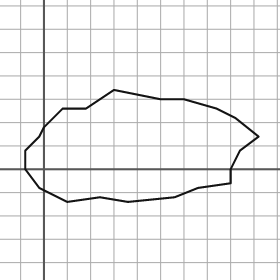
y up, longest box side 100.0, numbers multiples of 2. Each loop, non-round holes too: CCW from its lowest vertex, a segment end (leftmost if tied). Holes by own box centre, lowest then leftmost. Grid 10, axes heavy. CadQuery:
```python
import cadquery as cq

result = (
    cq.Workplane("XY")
    .moveTo(10.0, -14.0)
    .lineTo(24.0, -12.0)
    .lineTo(36.0, -14.0)
    .lineTo(56.0, -12.0)
    .lineTo(66.0, -8.0)
    .lineTo(80.0, -6.0)
    .lineTo(80.0, 0.0)
    .lineTo(84.0, 8.0)
    .lineTo(92.0, 14.0)
    .lineTo(82.0, 22.0)
    .lineTo(74.0, 26.0)
    .lineTo(60.0, 30.0)
    .lineTo(50.0, 30.0)
    .lineTo(30.0, 34.0)
    .lineTo(18.0, 26.0)
    .lineTo(8.0, 26.0)
    .lineTo(0.0, 18.0)
    .lineTo(-2.0, 14.0)
    .lineTo(-8.0, 8.0)
    .lineTo(-8.0, 0.0)
    .lineTo(-2.0, -8.0)
    .close()
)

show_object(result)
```